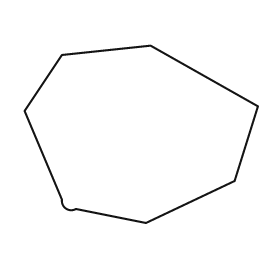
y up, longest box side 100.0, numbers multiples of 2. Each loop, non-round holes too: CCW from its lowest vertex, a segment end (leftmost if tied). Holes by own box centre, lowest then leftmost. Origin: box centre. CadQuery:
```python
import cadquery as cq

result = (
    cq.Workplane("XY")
    .moveTo(2.0, -38.0)
    .lineTo(40.0, -20.0)
    .lineTo(50.0, 12.0)
    .lineTo(4.0, 38.0)
    .lineTo(-34.0, 34.0)
    .lineTo(-50.0, 10.0)
    .lineTo(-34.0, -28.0)
    .threePointArc((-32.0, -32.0), (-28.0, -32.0))
    .close()
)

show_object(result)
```